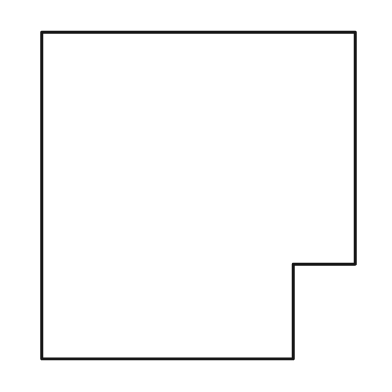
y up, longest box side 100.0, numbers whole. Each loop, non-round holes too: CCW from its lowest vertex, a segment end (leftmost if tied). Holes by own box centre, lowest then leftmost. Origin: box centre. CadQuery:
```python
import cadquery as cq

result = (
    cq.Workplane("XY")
    .moveTo(-48.0, -50.0)
    .lineTo(29.0, -50.0)
    .lineTo(29.0, -21.0)
    .lineTo(48.0, -21.0)
    .lineTo(48.0, 50.0)
    .lineTo(-48.0, 50.0)
    .close()
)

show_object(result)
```